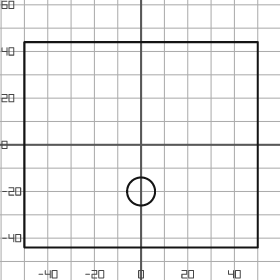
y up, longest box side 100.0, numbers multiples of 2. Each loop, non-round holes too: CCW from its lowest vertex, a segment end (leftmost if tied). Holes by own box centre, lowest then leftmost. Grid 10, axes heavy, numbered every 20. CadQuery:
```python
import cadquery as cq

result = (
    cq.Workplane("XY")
    .moveTo(-50.0, -44.0)
    .lineTo(50.0, -44.0)
    .lineTo(50.0, 44.0)
    .lineTo(-50.0, 44.0)
    .close()
    .moveTo(0.0, -20.0)
    .circle(6.0)
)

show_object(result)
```